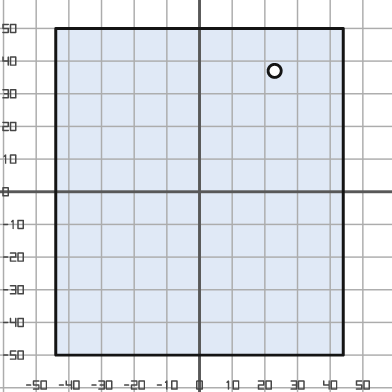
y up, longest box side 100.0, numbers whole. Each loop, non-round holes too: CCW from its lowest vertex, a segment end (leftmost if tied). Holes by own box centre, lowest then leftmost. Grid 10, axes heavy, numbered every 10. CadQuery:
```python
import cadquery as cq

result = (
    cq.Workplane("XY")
    .moveTo(-44.0, -50.0)
    .lineTo(44.0, -50.0)
    .lineTo(44.0, 50.0)
    .lineTo(-44.0, 50.0)
    .close()
    .moveTo(23.0, 37.0)
    .circle(2.0)
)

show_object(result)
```